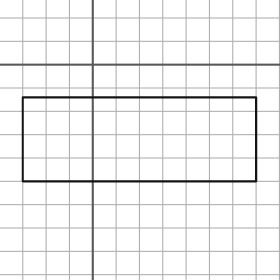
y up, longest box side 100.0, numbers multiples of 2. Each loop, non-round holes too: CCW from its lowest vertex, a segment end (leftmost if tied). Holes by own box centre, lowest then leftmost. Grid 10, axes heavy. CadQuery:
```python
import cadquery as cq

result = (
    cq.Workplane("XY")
    .moveTo(-30.0, -50.0)
    .lineTo(70.0, -50.0)
    .lineTo(70.0, -14.0)
    .lineTo(-30.0, -14.0)
    .close()
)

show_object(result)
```